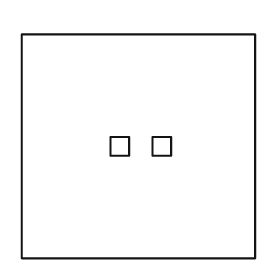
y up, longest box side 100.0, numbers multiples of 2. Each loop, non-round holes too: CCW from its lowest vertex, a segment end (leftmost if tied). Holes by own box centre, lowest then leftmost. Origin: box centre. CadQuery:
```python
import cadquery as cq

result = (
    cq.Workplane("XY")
    .moveTo(-50.0, -48.0)
    .lineTo(50.0, -48.0)
    .lineTo(50.0, 48.0)
    .lineTo(-50.0, 48.0)
    .close()
    .moveTo(-12.0, -4.0)
    .lineTo(-4.0, -4.0)
    .lineTo(-4.0, 4.0)
    .lineTo(-12.0, 4.0)
    .close()
    .moveTo(6.0, -4.0)
    .lineTo(14.0, -4.0)
    .lineTo(14.0, 4.0)
    .lineTo(6.0, 4.0)
    .close()
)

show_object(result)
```